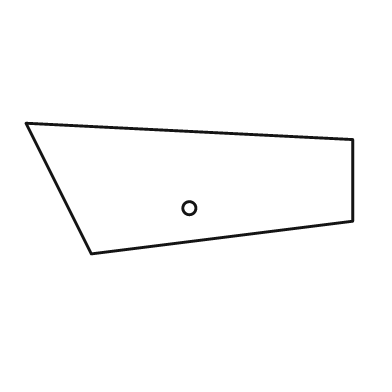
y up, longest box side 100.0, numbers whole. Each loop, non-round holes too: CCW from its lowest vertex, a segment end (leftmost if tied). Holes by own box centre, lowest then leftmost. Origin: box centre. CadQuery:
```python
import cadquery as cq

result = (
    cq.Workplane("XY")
    .moveTo(-30.0, -20.0)
    .lineTo(50.0, -10.0)
    .lineTo(50.0, 15.0)
    .lineTo(-50.0, 20.0)
    .close()
    .moveTo(0.0, -6.0)
    .circle(2.0)
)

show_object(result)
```